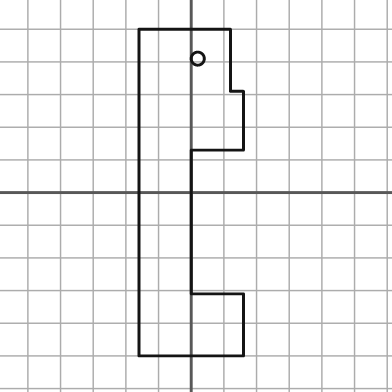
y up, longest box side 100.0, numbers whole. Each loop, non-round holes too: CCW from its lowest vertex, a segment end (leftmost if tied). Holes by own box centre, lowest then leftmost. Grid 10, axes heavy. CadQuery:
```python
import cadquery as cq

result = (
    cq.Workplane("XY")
    .moveTo(-16.0, -50.0)
    .lineTo(16.0, -50.0)
    .lineTo(16.0, -31.0)
    .lineTo(0.0, -31.0)
    .lineTo(0.0, 13.0)
    .lineTo(16.0, 13.0)
    .lineTo(16.0, 31.0)
    .lineTo(12.0, 31.0)
    .lineTo(12.0, 50.0)
    .lineTo(-16.0, 50.0)
    .close()
    .moveTo(2.0, 41.0)
    .circle(2.0)
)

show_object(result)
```